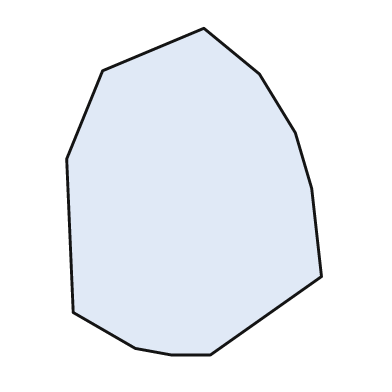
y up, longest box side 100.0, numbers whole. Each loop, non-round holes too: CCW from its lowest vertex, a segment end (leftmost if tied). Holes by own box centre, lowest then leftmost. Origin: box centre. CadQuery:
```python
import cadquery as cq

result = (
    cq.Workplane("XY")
    .moveTo(-7.0, -50.0)
    .lineTo(5.0, -50.0)
    .lineTo(39.0, -26.0)
    .lineTo(36.0, 1.0)
    .lineTo(31.0, 18.0)
    .lineTo(20.0, 36.0)
    .lineTo(3.0, 50.0)
    .lineTo(-28.0, 37.0)
    .lineTo(-39.0, 10.0)
    .lineTo(-37.0, -37.0)
    .lineTo(-18.0, -48.0)
    .close()
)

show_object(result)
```